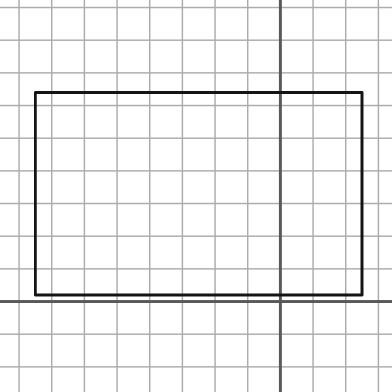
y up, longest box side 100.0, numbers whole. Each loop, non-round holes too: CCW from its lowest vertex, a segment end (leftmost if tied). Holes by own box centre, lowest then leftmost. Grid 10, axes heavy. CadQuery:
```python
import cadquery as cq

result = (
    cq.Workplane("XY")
    .moveTo(-75.0, 2.0)
    .lineTo(25.0, 2.0)
    .lineTo(25.0, 64.0)
    .lineTo(-75.0, 64.0)
    .close()
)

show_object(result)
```